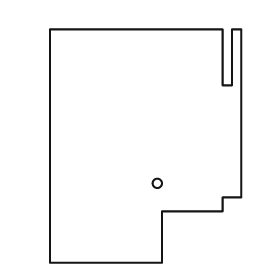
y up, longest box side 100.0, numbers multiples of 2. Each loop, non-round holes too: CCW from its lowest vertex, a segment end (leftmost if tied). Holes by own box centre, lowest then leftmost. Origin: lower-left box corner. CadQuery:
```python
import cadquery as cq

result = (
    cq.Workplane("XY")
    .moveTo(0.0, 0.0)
    .lineTo(48.0, 0.0)
    .lineTo(48.0, 22.0)
    .lineTo(74.0, 22.0)
    .lineTo(74.0, 28.0)
    .lineTo(82.0, 28.0)
    .lineTo(82.0, 100.0)
    .lineTo(78.0, 100.0)
    .lineTo(78.0, 76.0)
    .lineTo(74.0, 76.0)
    .lineTo(74.0, 100.0)
    .lineTo(0.0, 100.0)
    .close()
    .moveTo(46.0, 34.0)
    .circle(2.0)
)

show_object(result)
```